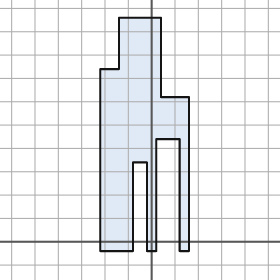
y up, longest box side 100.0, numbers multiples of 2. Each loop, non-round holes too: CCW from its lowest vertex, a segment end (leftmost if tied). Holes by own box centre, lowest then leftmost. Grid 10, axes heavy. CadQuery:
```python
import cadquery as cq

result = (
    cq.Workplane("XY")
    .moveTo(-22.0, -4.0)
    .lineTo(-8.0, -4.0)
    .lineTo(-8.0, 34.0)
    .lineTo(-2.0, 34.0)
    .lineTo(-2.0, -4.0)
    .lineTo(2.0, -4.0)
    .lineTo(2.0, 44.0)
    .lineTo(12.0, 44.0)
    .lineTo(12.0, -4.0)
    .lineTo(16.0, -4.0)
    .lineTo(16.0, 62.0)
    .lineTo(4.0, 62.0)
    .lineTo(4.0, 96.0)
    .lineTo(-14.0, 96.0)
    .lineTo(-14.0, 74.0)
    .lineTo(-22.0, 74.0)
    .close()
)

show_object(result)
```